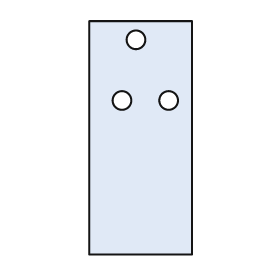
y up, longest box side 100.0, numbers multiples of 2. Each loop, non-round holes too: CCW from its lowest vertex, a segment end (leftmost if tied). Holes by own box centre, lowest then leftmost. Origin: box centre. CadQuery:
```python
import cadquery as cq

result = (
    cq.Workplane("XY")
    .moveTo(-22.0, -50.0)
    .lineTo(22.0, -50.0)
    .lineTo(22.0, 50.0)
    .lineTo(-22.0, 50.0)
    .close()
    .moveTo(-8.0, 16.0)
    .circle(4.0)
    .moveTo(12.0, 16.0)
    .circle(4.0)
    .moveTo(-2.0, 42.0)
    .circle(4.0)
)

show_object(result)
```